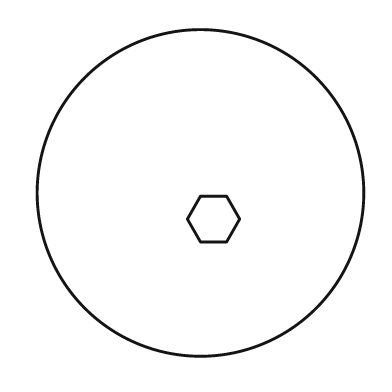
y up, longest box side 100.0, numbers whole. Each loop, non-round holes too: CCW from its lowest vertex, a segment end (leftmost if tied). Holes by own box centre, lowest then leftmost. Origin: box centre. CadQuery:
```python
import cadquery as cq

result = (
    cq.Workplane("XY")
    .moveTo(0.0, 0.0)
    .circle(50.0)
    .moveTo(0.0, -15.0)
    .lineTo(8.0, -15.0)
    .lineTo(12.0, -8.0)
    .lineTo(8.0, -1.0)
    .lineTo(0.0, -1.0)
    .lineTo(-4.0, -8.0)
    .close()
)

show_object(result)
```